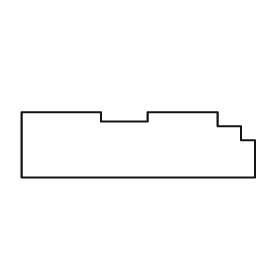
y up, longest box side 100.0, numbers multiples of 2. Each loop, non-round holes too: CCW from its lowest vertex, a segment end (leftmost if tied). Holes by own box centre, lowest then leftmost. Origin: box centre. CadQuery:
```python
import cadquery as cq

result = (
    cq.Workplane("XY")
    .moveTo(-50.0, -14.0)
    .lineTo(50.0, -14.0)
    .lineTo(50.0, 2.0)
    .lineTo(44.0, 2.0)
    .lineTo(44.0, 8.0)
    .lineTo(34.0, 8.0)
    .lineTo(34.0, 14.0)
    .lineTo(4.0, 14.0)
    .lineTo(4.0, 10.0)
    .lineTo(-16.0, 10.0)
    .lineTo(-16.0, 14.0)
    .lineTo(-50.0, 14.0)
    .close()
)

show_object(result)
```